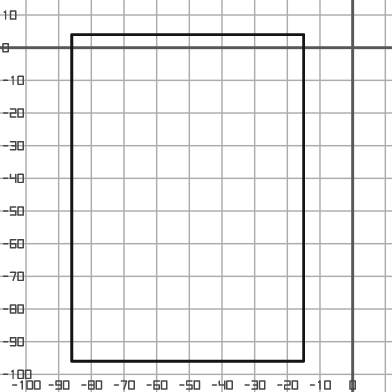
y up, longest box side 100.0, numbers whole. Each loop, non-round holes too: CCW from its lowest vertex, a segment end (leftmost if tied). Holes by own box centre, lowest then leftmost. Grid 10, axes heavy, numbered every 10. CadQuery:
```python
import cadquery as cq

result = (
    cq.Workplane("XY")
    .moveTo(-86.0, -96.0)
    .lineTo(-15.0, -96.0)
    .lineTo(-15.0, 4.0)
    .lineTo(-86.0, 4.0)
    .close()
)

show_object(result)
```